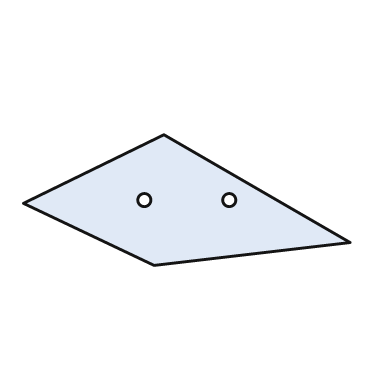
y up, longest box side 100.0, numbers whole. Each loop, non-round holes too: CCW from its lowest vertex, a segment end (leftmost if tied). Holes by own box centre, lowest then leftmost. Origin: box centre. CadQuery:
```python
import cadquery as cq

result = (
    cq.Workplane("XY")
    .moveTo(-10.0, -20.0)
    .lineTo(50.0, -13.0)
    .lineTo(-7.0, 20.0)
    .lineTo(-50.0, -1.0)
    .close()
    .moveTo(-13.0, 0.0)
    .circle(2.0)
    .moveTo(13.0, 0.0)
    .circle(2.0)
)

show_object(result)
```